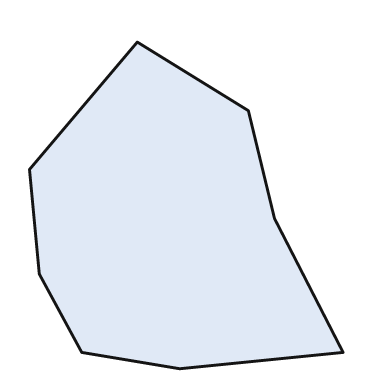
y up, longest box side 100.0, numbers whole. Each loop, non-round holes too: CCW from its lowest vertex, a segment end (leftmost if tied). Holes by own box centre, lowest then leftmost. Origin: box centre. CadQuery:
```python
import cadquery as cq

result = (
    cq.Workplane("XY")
    .moveTo(-2.0, -50.0)
    .lineTo(48.0, -45.0)
    .lineTo(27.0, -4.0)
    .lineTo(19.0, 29.0)
    .lineTo(-15.0, 50.0)
    .lineTo(-48.0, 11.0)
    .lineTo(-45.0, -21.0)
    .lineTo(-32.0, -45.0)
    .close()
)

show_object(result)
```